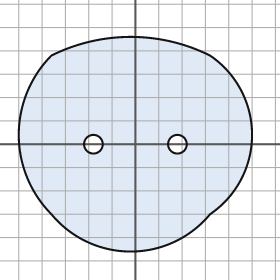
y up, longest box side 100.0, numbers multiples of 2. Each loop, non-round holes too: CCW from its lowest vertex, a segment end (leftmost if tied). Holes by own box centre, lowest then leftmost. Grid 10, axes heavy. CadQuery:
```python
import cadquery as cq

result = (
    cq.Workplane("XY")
    .moveTo(-36.0, -30.0)
    .threePointArc((-2.0, -46.0), (32.0, -30.0))
    .threePointArc((50.0, 4.0), (32.0, 38.0))
    .threePointArc((-2.0, 46.0), (-36.0, 38.0))
    .threePointArc((-50.0, 4.0), (-36.0, -30.0))
    .close()
    .moveTo(-18.0, 0.0)
    .circle(4.0)
    .moveTo(18.0, 0.0)
    .circle(4.0)
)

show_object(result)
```